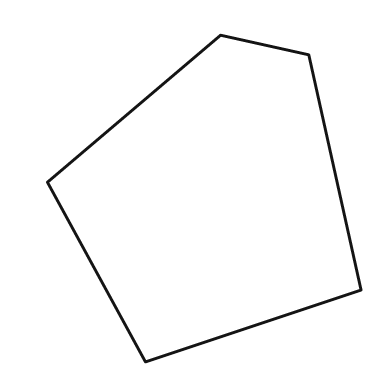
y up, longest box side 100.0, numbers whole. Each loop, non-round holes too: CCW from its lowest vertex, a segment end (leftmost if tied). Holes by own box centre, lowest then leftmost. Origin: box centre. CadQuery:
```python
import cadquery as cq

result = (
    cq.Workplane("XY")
    .moveTo(-18.0, -50.0)
    .lineTo(48.0, -28.0)
    .lineTo(32.0, 44.0)
    .lineTo(5.0, 50.0)
    .lineTo(-48.0, 5.0)
    .close()
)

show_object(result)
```